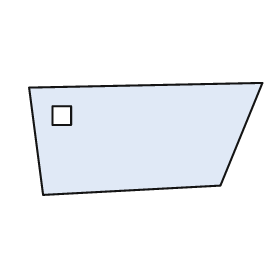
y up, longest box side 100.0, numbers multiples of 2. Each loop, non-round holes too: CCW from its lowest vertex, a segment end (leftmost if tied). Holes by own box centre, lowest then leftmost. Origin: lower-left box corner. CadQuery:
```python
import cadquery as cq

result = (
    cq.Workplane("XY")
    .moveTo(6.0, 0.0)
    .lineTo(82.0, 4.0)
    .lineTo(100.0, 48.0)
    .lineTo(0.0, 46.0)
    .close()
    .moveTo(10.0, 30.0)
    .lineTo(18.0, 30.0)
    .lineTo(18.0, 38.0)
    .lineTo(10.0, 38.0)
    .close()
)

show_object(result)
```